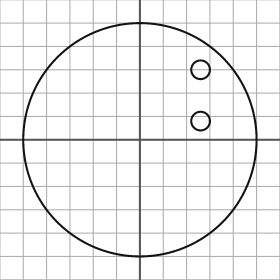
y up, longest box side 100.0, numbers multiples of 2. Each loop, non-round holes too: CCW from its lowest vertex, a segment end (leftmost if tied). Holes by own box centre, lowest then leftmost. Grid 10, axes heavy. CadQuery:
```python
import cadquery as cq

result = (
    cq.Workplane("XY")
    .moveTo(0.0, 0.0)
    .circle(50.0)
    .moveTo(26.0, 8.0)
    .circle(4.0)
    .moveTo(26.0, 30.0)
    .circle(4.0)
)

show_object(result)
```